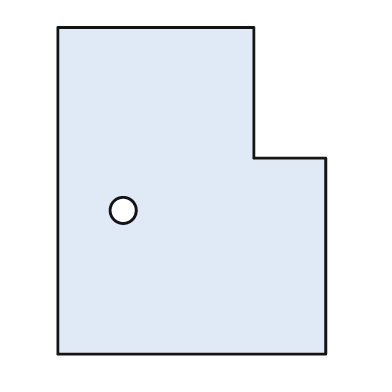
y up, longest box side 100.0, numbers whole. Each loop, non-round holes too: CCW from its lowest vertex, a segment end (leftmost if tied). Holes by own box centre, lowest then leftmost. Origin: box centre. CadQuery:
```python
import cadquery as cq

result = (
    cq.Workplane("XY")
    .moveTo(-41.0, -50.0)
    .lineTo(41.0, -50.0)
    .lineTo(41.0, 10.0)
    .lineTo(19.0, 10.0)
    .lineTo(19.0, 50.0)
    .lineTo(-41.0, 50.0)
    .close()
    .moveTo(-21.0, -6.0)
    .circle(4.0)
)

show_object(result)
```